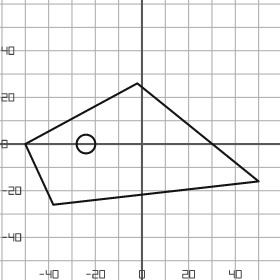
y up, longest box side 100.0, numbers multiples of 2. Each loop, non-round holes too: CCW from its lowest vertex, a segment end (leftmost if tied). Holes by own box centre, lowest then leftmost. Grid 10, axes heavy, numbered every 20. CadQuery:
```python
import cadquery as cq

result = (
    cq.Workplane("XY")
    .moveTo(-38.0, -26.0)
    .lineTo(50.0, -16.0)
    .lineTo(-2.0, 26.0)
    .lineTo(-50.0, 0.0)
    .close()
    .moveTo(-24.0, 0.0)
    .circle(4.0)
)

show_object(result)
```